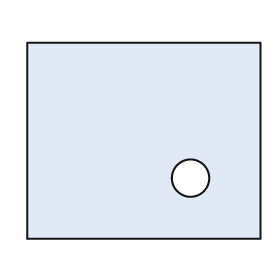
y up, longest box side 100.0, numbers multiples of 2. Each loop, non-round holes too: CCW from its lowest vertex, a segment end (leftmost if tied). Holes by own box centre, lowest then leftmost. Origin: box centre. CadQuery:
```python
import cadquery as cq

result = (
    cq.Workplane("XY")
    .moveTo(-50.0, -42.0)
    .lineTo(50.0, -42.0)
    .lineTo(50.0, 42.0)
    .lineTo(-50.0, 42.0)
    .close()
    .moveTo(20.0, -16.0)
    .circle(8.0)
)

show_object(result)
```